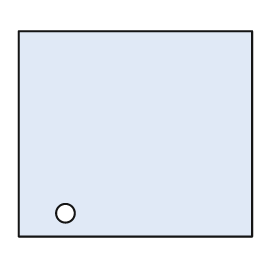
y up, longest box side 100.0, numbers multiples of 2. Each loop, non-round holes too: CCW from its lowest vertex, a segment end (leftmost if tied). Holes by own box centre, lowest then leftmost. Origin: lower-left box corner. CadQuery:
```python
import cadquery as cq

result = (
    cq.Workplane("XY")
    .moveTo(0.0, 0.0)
    .lineTo(100.0, 0.0)
    .lineTo(100.0, 88.0)
    .lineTo(0.0, 88.0)
    .close()
    .moveTo(20.0, 10.0)
    .circle(4.0)
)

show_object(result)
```